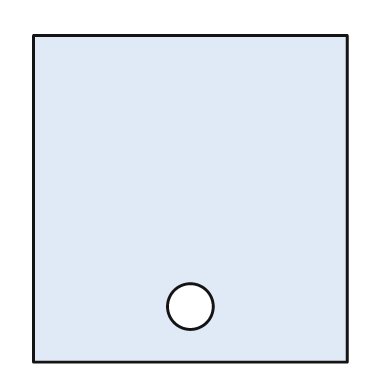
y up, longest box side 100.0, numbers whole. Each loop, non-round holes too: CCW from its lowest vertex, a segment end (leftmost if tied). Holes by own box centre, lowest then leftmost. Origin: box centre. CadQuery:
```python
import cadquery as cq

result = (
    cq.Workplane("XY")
    .moveTo(-48.0, -50.0)
    .lineTo(48.0, -50.0)
    .lineTo(48.0, 50.0)
    .lineTo(-48.0, 50.0)
    .close()
    .moveTo(0.0, -33.0)
    .circle(7.0)
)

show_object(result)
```